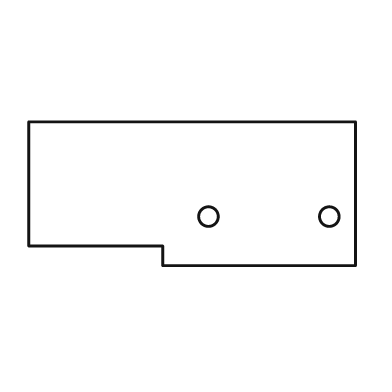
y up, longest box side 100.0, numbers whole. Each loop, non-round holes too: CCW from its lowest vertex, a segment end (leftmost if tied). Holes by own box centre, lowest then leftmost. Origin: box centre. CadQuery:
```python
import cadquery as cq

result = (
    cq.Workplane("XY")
    .moveTo(-9.0, -22.0)
    .lineTo(50.0, -22.0)
    .lineTo(50.0, 22.0)
    .lineTo(-50.0, 22.0)
    .lineTo(-50.0, -16.0)
    .lineTo(-9.0, -16.0)
    .close()
    .moveTo(5.0, -7.0)
    .circle(3.0)
    .moveTo(42.0, -7.0)
    .circle(3.0)
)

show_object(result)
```